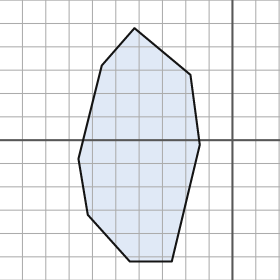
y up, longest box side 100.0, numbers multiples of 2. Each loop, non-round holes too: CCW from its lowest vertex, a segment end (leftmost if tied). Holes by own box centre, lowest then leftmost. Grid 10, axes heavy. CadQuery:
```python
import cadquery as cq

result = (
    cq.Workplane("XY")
    .moveTo(-44.0, -52.0)
    .lineTo(-26.0, -52.0)
    .lineTo(-14.0, -2.0)
    .lineTo(-18.0, 28.0)
    .lineTo(-42.0, 48.0)
    .lineTo(-56.0, 32.0)
    .lineTo(-66.0, -8.0)
    .lineTo(-62.0, -32.0)
    .close()
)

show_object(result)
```